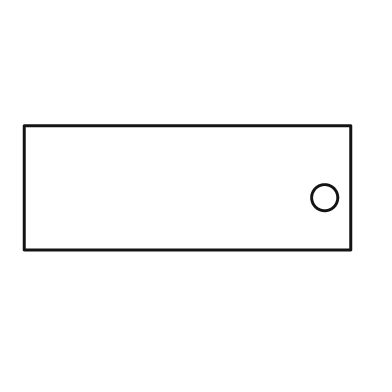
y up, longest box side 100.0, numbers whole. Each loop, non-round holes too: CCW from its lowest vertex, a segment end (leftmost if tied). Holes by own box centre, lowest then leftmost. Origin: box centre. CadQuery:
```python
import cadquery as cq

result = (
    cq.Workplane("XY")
    .moveTo(-50.0, -19.0)
    .lineTo(50.0, -19.0)
    .lineTo(50.0, 19.0)
    .lineTo(-50.0, 19.0)
    .close()
    .moveTo(42.0, -3.0)
    .circle(4.0)
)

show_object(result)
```